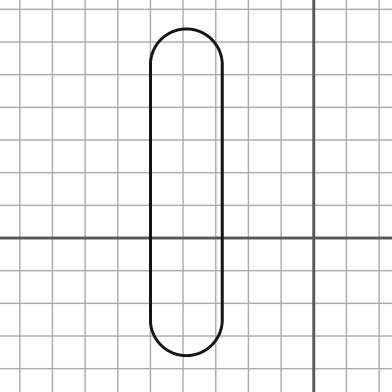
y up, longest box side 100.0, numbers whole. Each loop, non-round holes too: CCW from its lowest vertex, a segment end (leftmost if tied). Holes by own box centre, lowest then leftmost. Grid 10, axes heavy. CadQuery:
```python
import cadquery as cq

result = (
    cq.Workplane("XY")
    .moveTo(-50.0, -25.0)
    .threePointArc((-39.0, -36.0), (-28.0, -25.0))
    .lineTo(-28.0, 53.0)
    .threePointArc((-39.0, 64.0), (-50.0, 53.0))
    .close()
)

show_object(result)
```